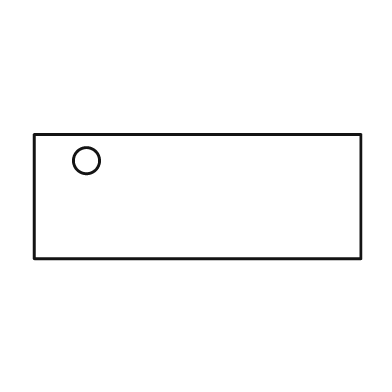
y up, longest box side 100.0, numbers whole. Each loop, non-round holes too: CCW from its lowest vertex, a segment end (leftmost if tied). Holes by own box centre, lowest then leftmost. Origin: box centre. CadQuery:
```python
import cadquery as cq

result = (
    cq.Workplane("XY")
    .moveTo(-50.0, -19.0)
    .lineTo(50.0, -19.0)
    .lineTo(50.0, 19.0)
    .lineTo(-50.0, 19.0)
    .close()
    .moveTo(-34.0, 11.0)
    .circle(4.0)
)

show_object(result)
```